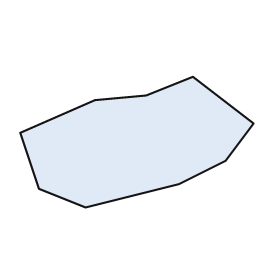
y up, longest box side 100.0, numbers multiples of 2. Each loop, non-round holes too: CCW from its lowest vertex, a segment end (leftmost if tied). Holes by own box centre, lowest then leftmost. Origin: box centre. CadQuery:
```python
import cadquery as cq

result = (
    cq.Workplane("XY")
    .moveTo(-22.0, -28.0)
    .lineTo(18.0, -18.0)
    .lineTo(38.0, -8.0)
    .lineTo(50.0, 8.0)
    .lineTo(24.0, 28.0)
    .lineTo(4.0, 20.0)
    .lineTo(-18.0, 18.0)
    .lineTo(-50.0, 4.0)
    .lineTo(-42.0, -20.0)
    .close()
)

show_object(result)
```